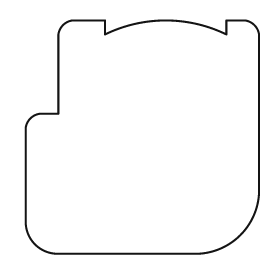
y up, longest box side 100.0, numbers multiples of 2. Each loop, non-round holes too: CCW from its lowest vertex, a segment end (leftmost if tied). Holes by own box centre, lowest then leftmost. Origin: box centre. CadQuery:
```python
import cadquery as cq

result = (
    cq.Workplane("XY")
    .moveTo(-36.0, -50.0)
    .lineTo(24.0, -50.0)
    .threePointArc((42.0, -42.0), (50.0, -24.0))
    .lineTo(50.0, 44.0)
    .threePointArc((48.0, 48.0), (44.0, 50.0))
    .lineTo(36.0, 50.0)
    .lineTo(36.0, 44.0)
    .threePointArc((10.0, 50.0), (-16.0, 44.0))
    .lineTo(-16.0, 50.0)
    .lineTo(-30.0, 50.0)
    .threePointArc((-34.0, 48.0), (-36.0, 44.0))
    .lineTo(-36.0, 10.0)
    .lineTo(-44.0, 10.0)
    .threePointArc((-48.0, 8.0), (-50.0, 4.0))
    .lineTo(-50.0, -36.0)
    .threePointArc((-46.0, -46.0), (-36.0, -50.0))
    .close()
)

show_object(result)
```